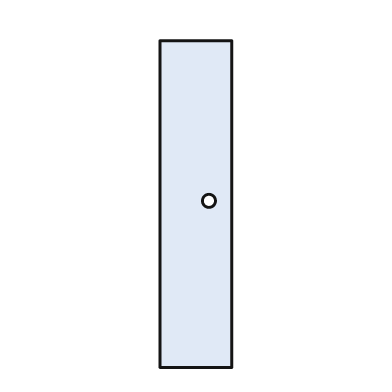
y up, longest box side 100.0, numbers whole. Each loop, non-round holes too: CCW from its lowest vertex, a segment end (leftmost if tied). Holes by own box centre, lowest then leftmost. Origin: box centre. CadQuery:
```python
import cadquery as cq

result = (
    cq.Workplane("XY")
    .moveTo(-11.0, -50.0)
    .lineTo(11.0, -50.0)
    .lineTo(11.0, 50.0)
    .lineTo(-11.0, 50.0)
    .close()
    .moveTo(4.0, 1.0)
    .circle(2.0)
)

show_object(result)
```